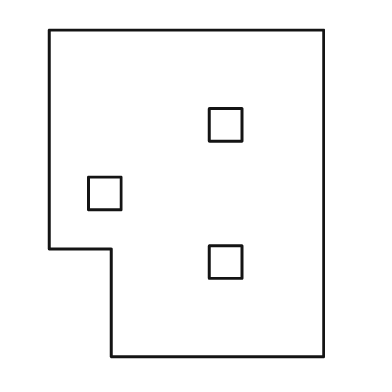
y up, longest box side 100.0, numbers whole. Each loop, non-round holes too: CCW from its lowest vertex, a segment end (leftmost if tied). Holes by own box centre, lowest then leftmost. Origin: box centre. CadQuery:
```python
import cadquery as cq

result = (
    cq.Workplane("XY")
    .moveTo(-23.0, -50.0)
    .lineTo(42.0, -50.0)
    .lineTo(42.0, 50.0)
    .lineTo(-42.0, 50.0)
    .lineTo(-42.0, -17.0)
    .lineTo(-23.0, -17.0)
    .close()
    .moveTo(7.0, -26.0)
    .lineTo(17.0, -26.0)
    .lineTo(17.0, -16.0)
    .lineTo(7.0, -16.0)
    .close()
    .moveTo(-30.0, -5.0)
    .lineTo(-20.0, -5.0)
    .lineTo(-20.0, 5.0)
    .lineTo(-30.0, 5.0)
    .close()
    .moveTo(7.0, 16.0)
    .lineTo(17.0, 16.0)
    .lineTo(17.0, 26.0)
    .lineTo(7.0, 26.0)
    .close()
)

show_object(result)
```